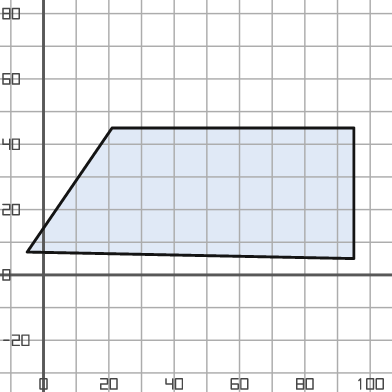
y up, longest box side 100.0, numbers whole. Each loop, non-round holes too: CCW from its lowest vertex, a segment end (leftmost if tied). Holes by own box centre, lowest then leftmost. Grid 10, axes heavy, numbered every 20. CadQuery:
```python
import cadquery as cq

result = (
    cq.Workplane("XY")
    .moveTo(95.0, 5.0)
    .lineTo(95.0, 45.0)
    .lineTo(21.0, 45.0)
    .lineTo(-5.0, 7.0)
    .close()
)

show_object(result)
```